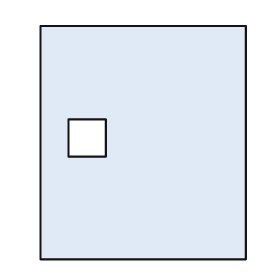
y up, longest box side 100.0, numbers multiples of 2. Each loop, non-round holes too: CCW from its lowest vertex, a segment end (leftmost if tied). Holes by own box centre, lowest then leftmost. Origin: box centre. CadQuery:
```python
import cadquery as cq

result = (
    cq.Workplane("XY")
    .moveTo(-44.0, -50.0)
    .lineTo(44.0, -50.0)
    .lineTo(44.0, 50.0)
    .lineTo(-44.0, 50.0)
    .close()
    .moveTo(-32.0, -6.0)
    .lineTo(-16.0, -6.0)
    .lineTo(-16.0, 10.0)
    .lineTo(-32.0, 10.0)
    .close()
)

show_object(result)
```